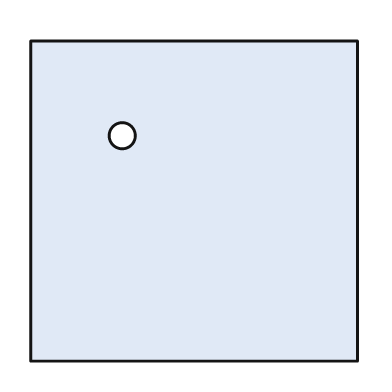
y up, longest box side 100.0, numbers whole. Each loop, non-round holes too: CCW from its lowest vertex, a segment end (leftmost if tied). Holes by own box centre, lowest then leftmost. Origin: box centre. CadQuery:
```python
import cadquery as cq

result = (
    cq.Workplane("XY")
    .moveTo(-50.0, -49.0)
    .lineTo(50.0, -49.0)
    .lineTo(50.0, 49.0)
    .lineTo(-50.0, 49.0)
    .close()
    .moveTo(-22.0, 20.0)
    .circle(4.0)
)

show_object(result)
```